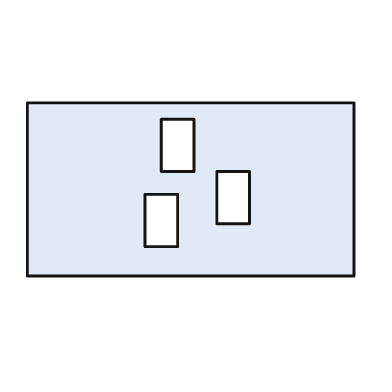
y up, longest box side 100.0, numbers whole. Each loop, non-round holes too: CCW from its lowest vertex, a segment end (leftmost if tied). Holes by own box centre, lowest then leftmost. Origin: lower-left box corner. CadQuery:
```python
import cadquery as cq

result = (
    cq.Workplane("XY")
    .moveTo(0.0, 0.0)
    .lineTo(100.0, 0.0)
    .lineTo(100.0, 53.0)
    .lineTo(0.0, 53.0)
    .close()
    .moveTo(36.0, 9.0)
    .lineTo(46.0, 9.0)
    .lineTo(46.0, 25.0)
    .lineTo(36.0, 25.0)
    .close()
    .moveTo(58.0, 16.0)
    .lineTo(68.0, 16.0)
    .lineTo(68.0, 32.0)
    .lineTo(58.0, 32.0)
    .close()
    .moveTo(41.0, 32.0)
    .lineTo(51.0, 32.0)
    .lineTo(51.0, 48.0)
    .lineTo(41.0, 48.0)
    .close()
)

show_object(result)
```